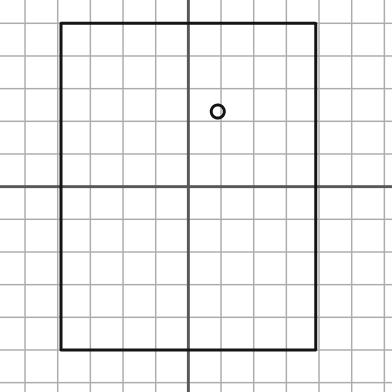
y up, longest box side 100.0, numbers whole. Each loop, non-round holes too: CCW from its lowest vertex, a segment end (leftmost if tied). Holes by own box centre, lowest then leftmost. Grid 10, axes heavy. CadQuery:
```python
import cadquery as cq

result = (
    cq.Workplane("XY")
    .moveTo(-39.0, -50.0)
    .lineTo(39.0, -50.0)
    .lineTo(39.0, 50.0)
    .lineTo(-39.0, 50.0)
    .close()
    .moveTo(9.0, 23.0)
    .circle(2.0)
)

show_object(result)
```